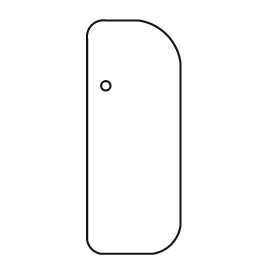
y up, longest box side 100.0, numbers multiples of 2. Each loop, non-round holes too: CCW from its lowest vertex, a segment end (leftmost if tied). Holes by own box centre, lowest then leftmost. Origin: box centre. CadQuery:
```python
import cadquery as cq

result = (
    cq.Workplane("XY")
    .moveTo(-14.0, -50.0)
    .lineTo(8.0, -50.0)
    .threePointArc((16.0, -46.0), (20.0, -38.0))
    .lineTo(20.0, 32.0)
    .threePointArc((14.0, 44.0), (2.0, 50.0))
    .lineTo(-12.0, 50.0)
    .threePointArc((-18.0, 48.0), (-20.0, 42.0))
    .lineTo(-20.0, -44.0)
    .threePointArc((-18.0, -48.0), (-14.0, -50.0))
    .close()
    .moveTo(-12.0, 22.0)
    .circle(2.0)
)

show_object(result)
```